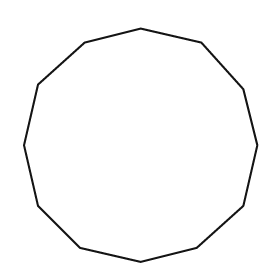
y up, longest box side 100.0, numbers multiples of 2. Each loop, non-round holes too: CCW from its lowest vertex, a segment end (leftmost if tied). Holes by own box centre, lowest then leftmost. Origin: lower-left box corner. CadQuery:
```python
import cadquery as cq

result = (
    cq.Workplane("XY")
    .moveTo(50.0, 0.0)
    .lineTo(74.0, 6.0)
    .lineTo(94.0, 24.0)
    .lineTo(100.0, 50.0)
    .lineTo(94.0, 74.0)
    .lineTo(76.0, 94.0)
    .lineTo(50.0, 100.0)
    .lineTo(26.0, 94.0)
    .lineTo(6.0, 76.0)
    .lineTo(0.0, 50.0)
    .lineTo(6.0, 24.0)
    .lineTo(24.0, 6.0)
    .close()
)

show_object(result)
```